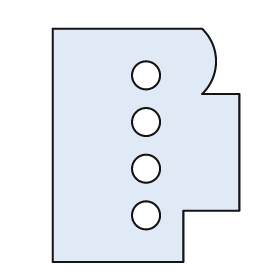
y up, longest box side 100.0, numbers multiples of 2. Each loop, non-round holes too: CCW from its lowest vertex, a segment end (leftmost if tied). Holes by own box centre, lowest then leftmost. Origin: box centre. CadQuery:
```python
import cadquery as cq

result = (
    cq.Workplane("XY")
    .moveTo(-40.0, -50.0)
    .lineTo(16.0, -50.0)
    .lineTo(16.0, -28.0)
    .lineTo(40.0, -28.0)
    .lineTo(40.0, 22.0)
    .lineTo(24.0, 22.0)
    .threePointArc((30.0, 36.0), (24.0, 50.0))
    .lineTo(-40.0, 50.0)
    .close()
    .moveTo(0.0, -30.0)
    .circle(6.0)
    .moveTo(0.0, -10.0)
    .circle(6.0)
    .moveTo(0.0, 10.0)
    .circle(6.0)
    .moveTo(0.0, 30.0)
    .circle(6.0)
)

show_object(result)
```